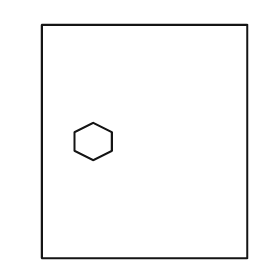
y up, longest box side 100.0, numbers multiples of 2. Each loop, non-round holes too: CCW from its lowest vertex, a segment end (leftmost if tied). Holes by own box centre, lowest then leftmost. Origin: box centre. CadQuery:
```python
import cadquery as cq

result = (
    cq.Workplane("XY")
    .moveTo(-44.0, -50.0)
    .lineTo(44.0, -50.0)
    .lineTo(44.0, 50.0)
    .lineTo(-44.0, 50.0)
    .close()
    .moveTo(-22.0, -8.0)
    .lineTo(-14.0, -4.0)
    .lineTo(-14.0, 4.0)
    .lineTo(-22.0, 8.0)
    .lineTo(-30.0, 4.0)
    .lineTo(-30.0, -4.0)
    .close()
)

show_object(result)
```